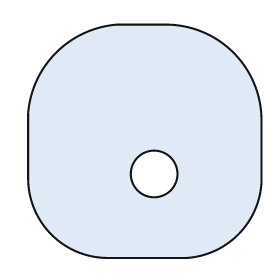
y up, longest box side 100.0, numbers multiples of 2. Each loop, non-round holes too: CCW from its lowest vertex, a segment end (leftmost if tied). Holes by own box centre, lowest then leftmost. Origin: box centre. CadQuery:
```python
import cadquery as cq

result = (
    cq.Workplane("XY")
    .moveTo(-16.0, -50.0)
    .lineTo(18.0, -50.0)
    .threePointArc((40.0, -40.0), (50.0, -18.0))
    .lineTo(50.0, 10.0)
    .threePointArc((38.0, 38.0), (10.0, 50.0))
    .lineTo(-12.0, 50.0)
    .threePointArc((-38.0, 38.0), (-50.0, 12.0))
    .lineTo(-50.0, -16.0)
    .threePointArc((-40.0, -40.0), (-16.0, -50.0))
    .close()
    .moveTo(4.0, -14.0)
    .circle(10.0)
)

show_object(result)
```